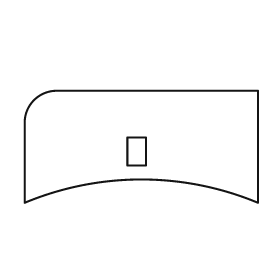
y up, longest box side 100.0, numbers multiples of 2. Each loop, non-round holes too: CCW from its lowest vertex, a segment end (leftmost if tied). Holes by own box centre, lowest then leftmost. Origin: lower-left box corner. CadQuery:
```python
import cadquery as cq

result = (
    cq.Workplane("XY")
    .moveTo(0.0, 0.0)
    .threePointArc((50.0, 10.0), (100.0, 0.0))
    .lineTo(100.0, 48.0)
    .lineTo(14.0, 48.0)
    .threePointArc((4.0, 44.0), (0.0, 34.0))
    .close()
    .moveTo(44.0, 16.0)
    .lineTo(52.0, 16.0)
    .lineTo(52.0, 28.0)
    .lineTo(44.0, 28.0)
    .close()
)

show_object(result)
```